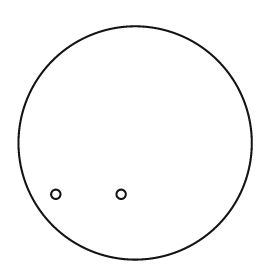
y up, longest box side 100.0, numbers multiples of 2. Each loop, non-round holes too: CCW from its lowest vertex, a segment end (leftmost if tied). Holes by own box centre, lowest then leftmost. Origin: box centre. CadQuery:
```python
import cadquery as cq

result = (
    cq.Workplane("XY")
    .moveTo(0.0, 0.0)
    .circle(50.0)
    .moveTo(-34.0, -22.0)
    .circle(2.0)
    .moveTo(-6.0, -22.0)
    .circle(2.0)
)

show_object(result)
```